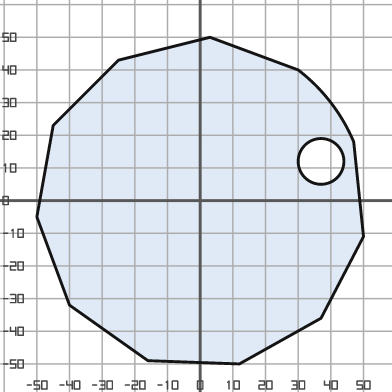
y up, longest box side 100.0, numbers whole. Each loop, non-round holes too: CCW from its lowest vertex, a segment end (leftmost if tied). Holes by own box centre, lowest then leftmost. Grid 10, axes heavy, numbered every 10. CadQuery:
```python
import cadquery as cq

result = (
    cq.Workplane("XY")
    .moveTo(12.0, -50.0)
    .lineTo(37.0, -36.0)
    .lineTo(50.0, -11.0)
    .lineTo(47.0, 18.0)
    .threePointArc((40.0, 30.0), (30.0, 40.0))
    .lineTo(3.0, 50.0)
    .lineTo(-25.0, 43.0)
    .lineTo(-45.0, 23.0)
    .lineTo(-50.0, -5.0)
    .lineTo(-40.0, -32.0)
    .lineTo(-16.0, -49.0)
    .close()
    .moveTo(37.0, 12.0)
    .circle(7.0)
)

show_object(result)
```